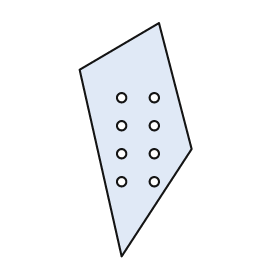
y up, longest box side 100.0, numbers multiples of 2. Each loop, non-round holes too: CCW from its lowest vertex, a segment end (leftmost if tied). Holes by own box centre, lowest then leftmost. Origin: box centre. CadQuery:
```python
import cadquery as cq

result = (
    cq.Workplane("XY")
    .moveTo(-6.0, -50.0)
    .lineTo(24.0, -4.0)
    .lineTo(10.0, 50.0)
    .lineTo(-24.0, 30.0)
    .close()
    .moveTo(-6.0, -18.0)
    .circle(2.0)
    .moveTo(8.0, -18.0)
    .circle(2.0)
    .moveTo(-6.0, -6.0)
    .circle(2.0)
    .moveTo(8.0, -6.0)
    .circle(2.0)
    .moveTo(-6.0, 6.0)
    .circle(2.0)
    .moveTo(8.0, 6.0)
    .circle(2.0)
    .moveTo(-6.0, 18.0)
    .circle(2.0)
    .moveTo(8.0, 18.0)
    .circle(2.0)
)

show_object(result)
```